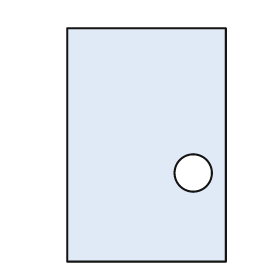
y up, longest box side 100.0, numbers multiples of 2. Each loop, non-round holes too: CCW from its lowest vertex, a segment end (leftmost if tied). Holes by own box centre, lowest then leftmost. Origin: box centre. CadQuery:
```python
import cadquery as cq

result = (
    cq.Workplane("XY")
    .moveTo(-34.0, -50.0)
    .lineTo(34.0, -50.0)
    .lineTo(34.0, 50.0)
    .lineTo(-34.0, 50.0)
    .close()
    .moveTo(20.0, -12.0)
    .circle(8.0)
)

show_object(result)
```